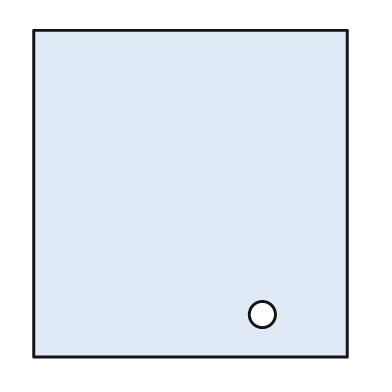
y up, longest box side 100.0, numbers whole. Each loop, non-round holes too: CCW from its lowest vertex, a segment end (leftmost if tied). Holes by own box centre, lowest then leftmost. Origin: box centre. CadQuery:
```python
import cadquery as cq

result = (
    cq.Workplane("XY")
    .moveTo(-48.0, -50.0)
    .lineTo(48.0, -50.0)
    .lineTo(48.0, 50.0)
    .lineTo(-48.0, 50.0)
    .close()
    .moveTo(22.0, -37.0)
    .circle(4.0)
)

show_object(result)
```